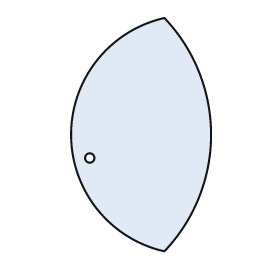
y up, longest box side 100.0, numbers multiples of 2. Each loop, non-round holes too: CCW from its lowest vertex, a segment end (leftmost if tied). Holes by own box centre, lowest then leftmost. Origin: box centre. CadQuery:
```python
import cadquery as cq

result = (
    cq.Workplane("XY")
    .moveTo(10.0, -50.0)
    .threePointArc((30.0, 0.0), (10.0, 50.0))
    .threePointArc((-30.0, 0.0), (10.0, -50.0))
    .close()
    .moveTo(-22.0, -10.0)
    .circle(2.0)
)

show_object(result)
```